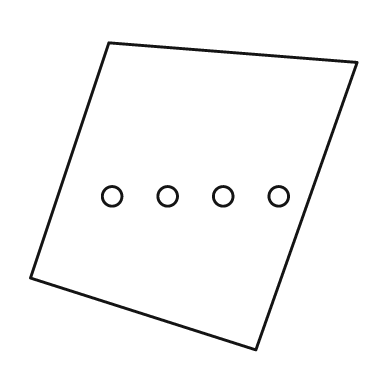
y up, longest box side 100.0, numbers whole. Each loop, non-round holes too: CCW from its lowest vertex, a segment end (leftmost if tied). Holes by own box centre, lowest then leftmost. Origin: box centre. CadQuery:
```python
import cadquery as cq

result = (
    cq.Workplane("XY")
    .moveTo(19.0, -47.0)
    .lineTo(50.0, 41.0)
    .lineTo(-26.0, 47.0)
    .lineTo(-50.0, -25.0)
    .close()
    .moveTo(-25.0, 0.0)
    .circle(3.0)
    .moveTo(-8.0, 0.0)
    .circle(3.0)
    .moveTo(9.0, 0.0)
    .circle(3.0)
    .moveTo(26.0, 0.0)
    .circle(3.0)
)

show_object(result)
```